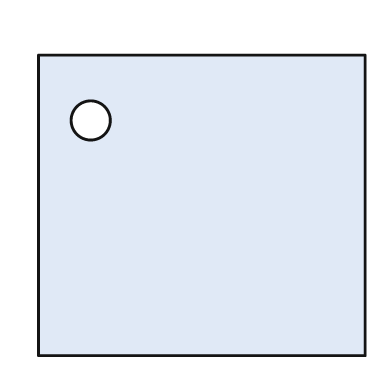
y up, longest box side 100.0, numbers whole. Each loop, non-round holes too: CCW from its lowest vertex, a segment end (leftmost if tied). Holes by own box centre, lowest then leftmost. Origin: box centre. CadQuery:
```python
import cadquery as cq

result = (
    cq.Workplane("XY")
    .moveTo(-50.0, -46.0)
    .lineTo(50.0, -46.0)
    .lineTo(50.0, 46.0)
    .lineTo(-50.0, 46.0)
    .close()
    .moveTo(-34.0, 26.0)
    .circle(6.0)
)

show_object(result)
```